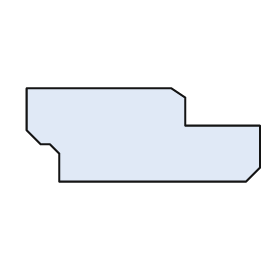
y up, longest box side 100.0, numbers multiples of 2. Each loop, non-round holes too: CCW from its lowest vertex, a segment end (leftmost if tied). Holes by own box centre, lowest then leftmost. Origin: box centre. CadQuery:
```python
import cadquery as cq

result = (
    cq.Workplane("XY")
    .moveTo(-36.0, -20.0)
    .lineTo(44.0, -20.0)
    .lineTo(50.0, -14.0)
    .lineTo(50.0, 4.0)
    .lineTo(18.0, 4.0)
    .lineTo(18.0, 16.0)
    .lineTo(12.0, 20.0)
    .lineTo(-50.0, 20.0)
    .lineTo(-50.0, 2.0)
    .lineTo(-44.0, -4.0)
    .lineTo(-40.0, -4.0)
    .lineTo(-36.0, -8.0)
    .close()
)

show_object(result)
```